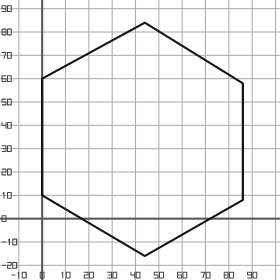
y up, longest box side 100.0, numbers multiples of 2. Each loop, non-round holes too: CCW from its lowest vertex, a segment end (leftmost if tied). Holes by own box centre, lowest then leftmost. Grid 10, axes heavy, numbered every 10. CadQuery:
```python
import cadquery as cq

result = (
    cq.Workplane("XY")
    .moveTo(44.0, -16.0)
    .lineTo(86.0, 8.0)
    .lineTo(86.0, 58.0)
    .lineTo(44.0, 84.0)
    .lineTo(0.0, 60.0)
    .lineTo(0.0, 10.0)
    .close()
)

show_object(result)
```